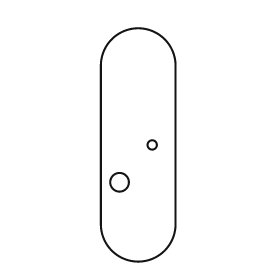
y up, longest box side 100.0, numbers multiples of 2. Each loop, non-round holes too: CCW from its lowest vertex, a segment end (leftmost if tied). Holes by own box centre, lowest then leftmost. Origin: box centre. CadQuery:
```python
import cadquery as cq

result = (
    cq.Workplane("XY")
    .moveTo(-16.0, -34.0)
    .threePointArc((0.0, -50.0), (16.0, -34.0))
    .lineTo(16.0, 34.0)
    .threePointArc((0.0, 50.0), (-16.0, 34.0))
    .close()
    .moveTo(-8.0, -16.0)
    .circle(4.0)
    .moveTo(6.0, 0.0)
    .circle(2.0)
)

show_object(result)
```